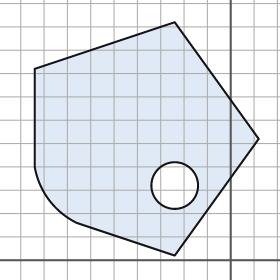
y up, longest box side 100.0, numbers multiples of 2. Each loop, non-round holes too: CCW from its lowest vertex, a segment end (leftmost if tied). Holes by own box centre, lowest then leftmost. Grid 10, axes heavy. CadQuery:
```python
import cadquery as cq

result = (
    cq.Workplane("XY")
    .moveTo(-24.0, 2.0)
    .lineTo(12.0, 52.0)
    .lineTo(-24.0, 102.0)
    .lineTo(-84.0, 82.0)
    .lineTo(-84.0, 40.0)
    .threePointArc((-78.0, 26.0), (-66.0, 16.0))
    .close()
    .moveTo(-24.0, 32.0)
    .circle(10.0)
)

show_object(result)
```